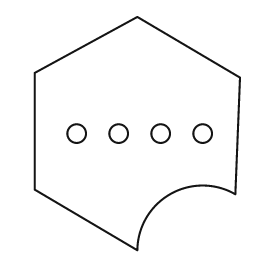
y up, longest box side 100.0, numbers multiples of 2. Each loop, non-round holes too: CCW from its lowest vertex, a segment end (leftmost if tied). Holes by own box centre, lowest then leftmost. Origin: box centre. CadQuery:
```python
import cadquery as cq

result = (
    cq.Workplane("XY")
    .moveTo(0.0, -50.0)
    .threePointArc((14.0, -26.0), (42.0, -26.0))
    .lineTo(44.0, 24.0)
    .lineTo(0.0, 50.0)
    .lineTo(-44.0, 26.0)
    .lineTo(-44.0, -24.0)
    .close()
    .moveTo(-26.0, 0.0)
    .circle(4.0)
    .moveTo(-8.0, 0.0)
    .circle(4.0)
    .moveTo(10.0, 0.0)
    .circle(4.0)
    .moveTo(28.0, 0.0)
    .circle(4.0)
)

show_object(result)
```